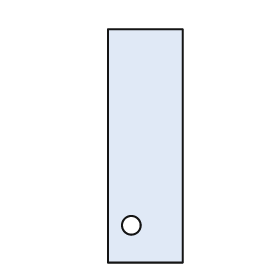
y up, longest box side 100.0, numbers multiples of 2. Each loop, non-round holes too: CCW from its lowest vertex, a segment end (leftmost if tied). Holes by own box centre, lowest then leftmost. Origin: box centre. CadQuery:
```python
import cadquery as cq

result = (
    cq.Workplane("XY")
    .moveTo(-16.0, -50.0)
    .lineTo(16.0, -50.0)
    .lineTo(16.0, 50.0)
    .lineTo(-16.0, 50.0)
    .close()
    .moveTo(-6.0, -34.0)
    .circle(4.0)
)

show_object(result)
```